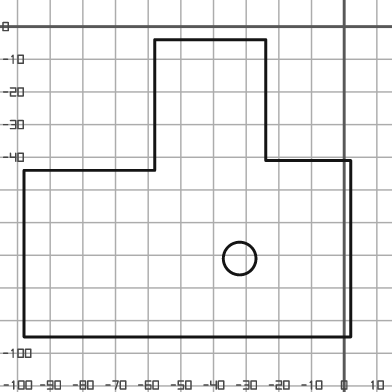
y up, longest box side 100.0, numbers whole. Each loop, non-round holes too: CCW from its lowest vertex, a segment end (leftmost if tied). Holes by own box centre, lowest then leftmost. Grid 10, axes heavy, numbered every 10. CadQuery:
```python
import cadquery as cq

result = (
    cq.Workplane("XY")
    .moveTo(-98.0, -95.0)
    .lineTo(2.0, -95.0)
    .lineTo(2.0, -41.0)
    .lineTo(-24.0, -41.0)
    .lineTo(-24.0, -4.0)
    .lineTo(-58.0, -4.0)
    .lineTo(-58.0, -44.0)
    .lineTo(-98.0, -44.0)
    .close()
    .moveTo(-32.0, -71.0)
    .circle(5.0)
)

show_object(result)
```